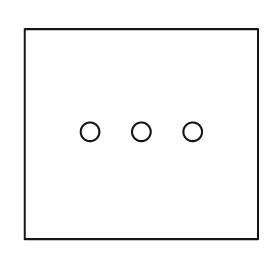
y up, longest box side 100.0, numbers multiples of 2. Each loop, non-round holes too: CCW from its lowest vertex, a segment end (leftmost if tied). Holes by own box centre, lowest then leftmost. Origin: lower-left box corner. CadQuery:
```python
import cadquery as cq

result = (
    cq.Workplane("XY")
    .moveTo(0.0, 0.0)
    .lineTo(100.0, 0.0)
    .lineTo(100.0, 90.0)
    .lineTo(0.0, 90.0)
    .close()
    .moveTo(28.0, 46.0)
    .circle(4.0)
    .moveTo(50.0, 46.0)
    .circle(4.0)
    .moveTo(72.0, 46.0)
    .circle(4.0)
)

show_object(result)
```